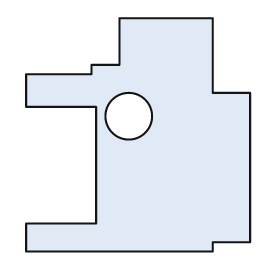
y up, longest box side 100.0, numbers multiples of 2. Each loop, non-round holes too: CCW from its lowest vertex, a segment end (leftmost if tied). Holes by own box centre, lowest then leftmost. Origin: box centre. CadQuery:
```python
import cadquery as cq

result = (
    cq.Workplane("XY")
    .moveTo(-48.0, -50.0)
    .lineTo(32.0, -50.0)
    .lineTo(32.0, -46.0)
    .lineTo(48.0, -46.0)
    .lineTo(48.0, 18.0)
    .lineTo(32.0, 18.0)
    .lineTo(32.0, 50.0)
    .lineTo(-8.0, 50.0)
    .lineTo(-8.0, 30.0)
    .lineTo(-20.0, 30.0)
    .lineTo(-20.0, 26.0)
    .lineTo(-48.0, 26.0)
    .lineTo(-48.0, 12.0)
    .lineTo(-18.0, 12.0)
    .lineTo(-18.0, -38.0)
    .lineTo(-48.0, -38.0)
    .close()
    .moveTo(-4.0, 8.0)
    .circle(10.0)
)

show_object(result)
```